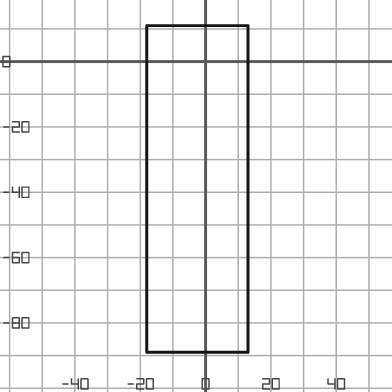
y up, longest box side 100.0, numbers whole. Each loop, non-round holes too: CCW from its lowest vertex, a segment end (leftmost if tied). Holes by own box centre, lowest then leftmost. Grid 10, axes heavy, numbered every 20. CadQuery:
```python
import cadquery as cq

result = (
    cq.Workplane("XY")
    .moveTo(-18.0, -89.0)
    .lineTo(13.0, -89.0)
    .lineTo(13.0, 11.0)
    .lineTo(-18.0, 11.0)
    .close()
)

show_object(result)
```